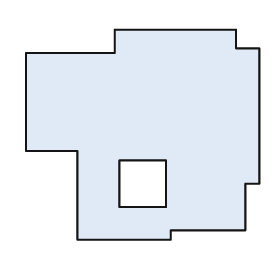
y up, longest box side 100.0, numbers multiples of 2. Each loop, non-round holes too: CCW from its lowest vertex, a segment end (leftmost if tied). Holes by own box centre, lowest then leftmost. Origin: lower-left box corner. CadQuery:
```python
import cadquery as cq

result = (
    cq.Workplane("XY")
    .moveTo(22.0, 0.0)
    .lineTo(62.0, 0.0)
    .lineTo(62.0, 4.0)
    .lineTo(94.0, 4.0)
    .lineTo(94.0, 24.0)
    .lineTo(100.0, 24.0)
    .lineTo(100.0, 82.0)
    .lineTo(90.0, 82.0)
    .lineTo(90.0, 90.0)
    .lineTo(38.0, 90.0)
    .lineTo(38.0, 80.0)
    .lineTo(0.0, 80.0)
    .lineTo(0.0, 38.0)
    .lineTo(22.0, 38.0)
    .close()
    .moveTo(40.0, 14.0)
    .lineTo(60.0, 14.0)
    .lineTo(60.0, 34.0)
    .lineTo(40.0, 34.0)
    .close()
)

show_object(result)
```